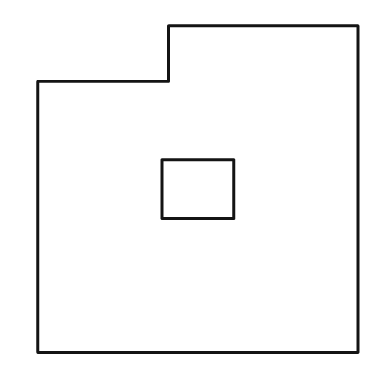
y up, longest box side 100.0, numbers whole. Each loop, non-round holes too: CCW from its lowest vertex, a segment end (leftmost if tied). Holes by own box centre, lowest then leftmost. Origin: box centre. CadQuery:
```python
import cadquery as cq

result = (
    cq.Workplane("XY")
    .moveTo(-49.0, -50.0)
    .lineTo(49.0, -50.0)
    .lineTo(49.0, 50.0)
    .lineTo(-9.0, 50.0)
    .lineTo(-9.0, 33.0)
    .lineTo(-49.0, 33.0)
    .close()
    .moveTo(-11.0, -9.0)
    .lineTo(11.0, -9.0)
    .lineTo(11.0, 9.0)
    .lineTo(-11.0, 9.0)
    .close()
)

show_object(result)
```